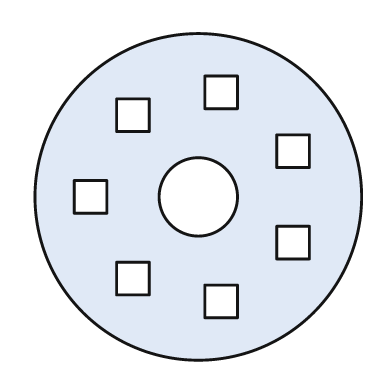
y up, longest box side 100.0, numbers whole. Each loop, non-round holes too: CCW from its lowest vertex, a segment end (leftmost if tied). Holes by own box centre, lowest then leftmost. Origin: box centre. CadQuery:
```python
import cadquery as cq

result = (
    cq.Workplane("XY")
    .moveTo(0.0, 0.0)
    .circle(50.0)
    .moveTo(2.0, -37.0)
    .lineTo(12.0, -37.0)
    .lineTo(12.0, -27.0)
    .lineTo(2.0, -27.0)
    .close()
    .moveTo(-25.0, -30.0)
    .lineTo(-15.0, -30.0)
    .lineTo(-15.0, -20.0)
    .lineTo(-25.0, -20.0)
    .close()
    .moveTo(24.0, -19.0)
    .lineTo(34.0, -19.0)
    .lineTo(34.0, -9.0)
    .lineTo(24.0, -9.0)
    .close()
    .moveTo(-38.0, -5.0)
    .lineTo(-28.0, -5.0)
    .lineTo(-28.0, 5.0)
    .lineTo(-38.0, 5.0)
    .close()
    .moveTo(0.0, 0.0)
    .circle(12.0)
    .moveTo(24.0, 9.0)
    .lineTo(34.0, 9.0)
    .lineTo(34.0, 19.0)
    .lineTo(24.0, 19.0)
    .close()
    .moveTo(-25.0, 20.0)
    .lineTo(-15.0, 20.0)
    .lineTo(-15.0, 30.0)
    .lineTo(-25.0, 30.0)
    .close()
    .moveTo(2.0, 27.0)
    .lineTo(12.0, 27.0)
    .lineTo(12.0, 37.0)
    .lineTo(2.0, 37.0)
    .close()
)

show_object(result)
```